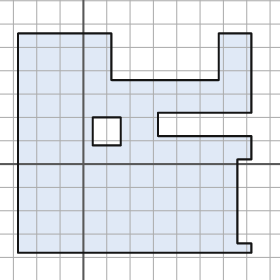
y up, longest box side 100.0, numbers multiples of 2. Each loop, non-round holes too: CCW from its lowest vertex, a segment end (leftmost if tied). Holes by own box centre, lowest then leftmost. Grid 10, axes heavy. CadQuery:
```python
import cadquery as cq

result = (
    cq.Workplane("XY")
    .moveTo(-28.0, -38.0)
    .lineTo(72.0, -38.0)
    .lineTo(72.0, -34.0)
    .lineTo(66.0, -34.0)
    .lineTo(66.0, 2.0)
    .lineTo(72.0, 2.0)
    .lineTo(72.0, 12.0)
    .lineTo(32.0, 12.0)
    .lineTo(32.0, 22.0)
    .lineTo(72.0, 22.0)
    .lineTo(72.0, 56.0)
    .lineTo(58.0, 56.0)
    .lineTo(58.0, 36.0)
    .lineTo(12.0, 36.0)
    .lineTo(12.0, 56.0)
    .lineTo(-28.0, 56.0)
    .close()
    .moveTo(4.0, 8.0)
    .lineTo(16.0, 8.0)
    .lineTo(16.0, 20.0)
    .lineTo(4.0, 20.0)
    .close()
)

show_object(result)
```